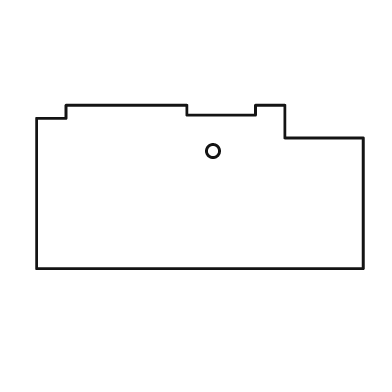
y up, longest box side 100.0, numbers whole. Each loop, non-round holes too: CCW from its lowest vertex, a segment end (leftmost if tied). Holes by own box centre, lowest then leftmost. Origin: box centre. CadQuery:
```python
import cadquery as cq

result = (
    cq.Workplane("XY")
    .moveTo(-50.0, -25.0)
    .lineTo(50.0, -25.0)
    .lineTo(50.0, 15.0)
    .lineTo(26.0, 15.0)
    .lineTo(26.0, 25.0)
    .lineTo(17.0, 25.0)
    .lineTo(17.0, 22.0)
    .lineTo(-4.0, 22.0)
    .lineTo(-4.0, 25.0)
    .lineTo(-41.0, 25.0)
    .lineTo(-41.0, 21.0)
    .lineTo(-50.0, 21.0)
    .close()
    .moveTo(4.0, 11.0)
    .circle(2.0)
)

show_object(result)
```